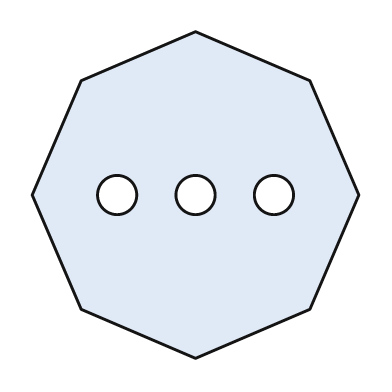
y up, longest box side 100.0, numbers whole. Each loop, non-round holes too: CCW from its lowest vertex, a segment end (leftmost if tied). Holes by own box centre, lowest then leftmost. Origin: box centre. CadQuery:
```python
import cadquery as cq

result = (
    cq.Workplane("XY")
    .moveTo(0.0, -50.0)
    .lineTo(35.0, -35.0)
    .lineTo(50.0, 0.0)
    .lineTo(35.0, 35.0)
    .lineTo(0.0, 50.0)
    .lineTo(-35.0, 35.0)
    .lineTo(-50.0, 0.0)
    .lineTo(-35.0, -35.0)
    .close()
    .moveTo(-24.0, 0.0)
    .circle(6.0)
    .moveTo(0.0, 0.0)
    .circle(6.0)
    .moveTo(24.0, 0.0)
    .circle(6.0)
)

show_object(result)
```